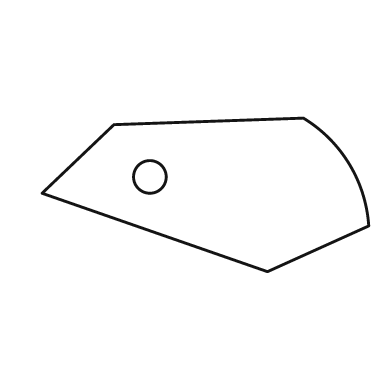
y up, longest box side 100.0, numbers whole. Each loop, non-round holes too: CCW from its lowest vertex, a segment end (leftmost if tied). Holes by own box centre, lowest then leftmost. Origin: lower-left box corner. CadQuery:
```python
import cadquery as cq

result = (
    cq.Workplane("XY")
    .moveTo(69.0, 0.0)
    .lineTo(100.0, 14.0)
    .threePointArc((94.0, 33.0), (80.0, 47.0))
    .lineTo(22.0, 45.0)
    .lineTo(0.0, 24.0)
    .close()
    .moveTo(33.0, 29.0)
    .circle(5.0)
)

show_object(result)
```